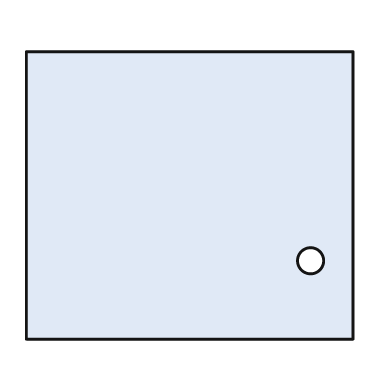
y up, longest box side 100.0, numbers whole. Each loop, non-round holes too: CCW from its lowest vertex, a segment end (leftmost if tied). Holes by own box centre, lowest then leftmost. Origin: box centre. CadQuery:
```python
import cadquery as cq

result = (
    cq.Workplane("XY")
    .moveTo(-50.0, -44.0)
    .lineTo(50.0, -44.0)
    .lineTo(50.0, 44.0)
    .lineTo(-50.0, 44.0)
    .close()
    .moveTo(37.0, -20.0)
    .circle(4.0)
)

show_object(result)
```